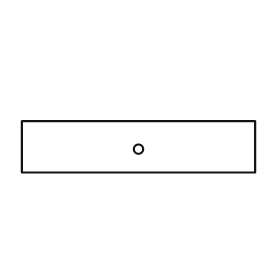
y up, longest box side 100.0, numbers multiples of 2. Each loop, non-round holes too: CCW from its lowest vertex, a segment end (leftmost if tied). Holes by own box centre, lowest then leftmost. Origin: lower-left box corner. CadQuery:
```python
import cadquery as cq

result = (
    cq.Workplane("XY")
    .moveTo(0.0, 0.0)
    .lineTo(100.0, 0.0)
    .lineTo(100.0, 22.0)
    .lineTo(0.0, 22.0)
    .close()
    .moveTo(50.0, 10.0)
    .circle(2.0)
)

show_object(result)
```